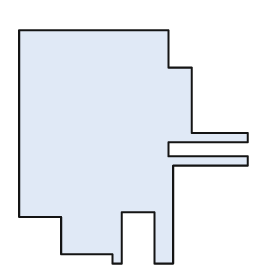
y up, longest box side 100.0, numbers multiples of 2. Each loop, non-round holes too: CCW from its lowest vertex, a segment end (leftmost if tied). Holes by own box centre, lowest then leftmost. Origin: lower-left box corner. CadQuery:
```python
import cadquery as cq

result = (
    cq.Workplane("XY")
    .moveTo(40.0, 0.0)
    .lineTo(44.0, 0.0)
    .lineTo(44.0, 22.0)
    .lineTo(58.0, 22.0)
    .lineTo(58.0, 0.0)
    .lineTo(66.0, 0.0)
    .lineTo(66.0, 42.0)
    .lineTo(98.0, 42.0)
    .lineTo(98.0, 46.0)
    .lineTo(64.0, 46.0)
    .lineTo(64.0, 52.0)
    .lineTo(98.0, 52.0)
    .lineTo(98.0, 56.0)
    .lineTo(74.0, 56.0)
    .lineTo(74.0, 84.0)
    .lineTo(64.0, 84.0)
    .lineTo(64.0, 100.0)
    .lineTo(0.0, 100.0)
    .lineTo(0.0, 20.0)
    .lineTo(18.0, 20.0)
    .lineTo(18.0, 4.0)
    .lineTo(40.0, 4.0)
    .close()
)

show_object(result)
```